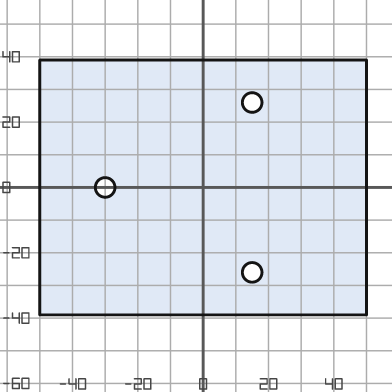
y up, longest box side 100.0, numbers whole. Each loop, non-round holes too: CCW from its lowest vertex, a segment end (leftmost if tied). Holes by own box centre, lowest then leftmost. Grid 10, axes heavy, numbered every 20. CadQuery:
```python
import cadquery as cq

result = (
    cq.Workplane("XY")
    .moveTo(-50.0, -39.0)
    .lineTo(50.0, -39.0)
    .lineTo(50.0, 39.0)
    .lineTo(-50.0, 39.0)
    .close()
    .moveTo(15.0, -26.0)
    .circle(3.0)
    .moveTo(-30.0, 0.0)
    .circle(3.0)
    .moveTo(15.0, 26.0)
    .circle(3.0)
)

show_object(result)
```